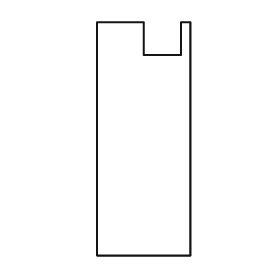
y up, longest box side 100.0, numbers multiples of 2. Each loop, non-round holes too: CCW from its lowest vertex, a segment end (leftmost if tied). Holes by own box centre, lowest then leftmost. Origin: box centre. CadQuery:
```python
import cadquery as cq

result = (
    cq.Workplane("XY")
    .moveTo(-20.0, -50.0)
    .lineTo(20.0, -50.0)
    .lineTo(20.0, 50.0)
    .lineTo(16.0, 50.0)
    .lineTo(16.0, 36.0)
    .lineTo(0.0, 36.0)
    .lineTo(0.0, 50.0)
    .lineTo(-20.0, 50.0)
    .close()
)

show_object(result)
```